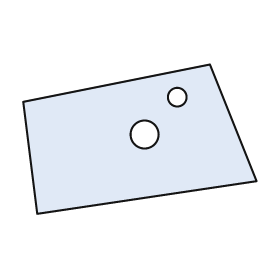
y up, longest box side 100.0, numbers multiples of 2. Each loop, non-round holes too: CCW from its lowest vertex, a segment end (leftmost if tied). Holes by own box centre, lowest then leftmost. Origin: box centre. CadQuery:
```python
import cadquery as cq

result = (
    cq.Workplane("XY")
    .moveTo(-44.0, -32.0)
    .lineTo(50.0, -18.0)
    .lineTo(30.0, 32.0)
    .lineTo(-50.0, 16.0)
    .close()
    .moveTo(2.0, 2.0)
    .circle(6.0)
    .moveTo(16.0, 18.0)
    .circle(4.0)
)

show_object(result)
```